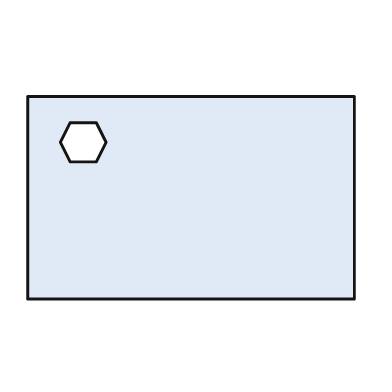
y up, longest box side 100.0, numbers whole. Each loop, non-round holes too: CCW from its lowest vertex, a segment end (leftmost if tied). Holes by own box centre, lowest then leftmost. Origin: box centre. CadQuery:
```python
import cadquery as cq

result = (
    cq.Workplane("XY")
    .moveTo(-50.0, -31.0)
    .lineTo(50.0, -31.0)
    .lineTo(50.0, 31.0)
    .lineTo(-50.0, 31.0)
    .close()
    .moveTo(-37.0, 11.0)
    .lineTo(-29.0, 11.0)
    .lineTo(-26.0, 17.0)
    .lineTo(-29.0, 23.0)
    .lineTo(-37.0, 23.0)
    .lineTo(-40.0, 17.0)
    .close()
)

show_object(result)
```